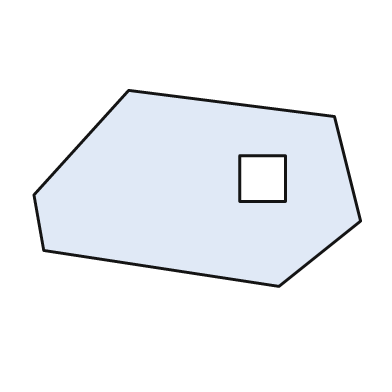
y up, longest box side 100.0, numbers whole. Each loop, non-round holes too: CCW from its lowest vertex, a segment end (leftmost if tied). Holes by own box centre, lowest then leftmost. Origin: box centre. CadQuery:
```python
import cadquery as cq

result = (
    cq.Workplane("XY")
    .moveTo(25.0, -30.0)
    .lineTo(50.0, -10.0)
    .lineTo(42.0, 22.0)
    .lineTo(-21.0, 30.0)
    .lineTo(-50.0, -2.0)
    .lineTo(-47.0, -19.0)
    .close()
    .moveTo(13.0, -4.0)
    .lineTo(27.0, -4.0)
    .lineTo(27.0, 10.0)
    .lineTo(13.0, 10.0)
    .close()
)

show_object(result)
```